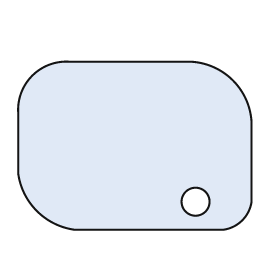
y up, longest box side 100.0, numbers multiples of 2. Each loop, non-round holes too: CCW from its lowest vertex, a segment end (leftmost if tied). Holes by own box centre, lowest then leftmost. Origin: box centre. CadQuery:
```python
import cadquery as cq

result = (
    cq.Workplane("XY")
    .moveTo(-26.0, -36.0)
    .lineTo(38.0, -36.0)
    .threePointArc((46.0, -32.0), (50.0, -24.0))
    .lineTo(50.0, 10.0)
    .threePointArc((42.0, 28.0), (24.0, 36.0))
    .lineTo(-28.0, 36.0)
    .threePointArc((-44.0, 30.0), (-50.0, 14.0))
    .lineTo(-50.0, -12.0)
    .threePointArc((-42.0, -28.0), (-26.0, -36.0))
    .close()
    .moveTo(26.0, -24.0)
    .circle(6.0)
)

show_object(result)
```